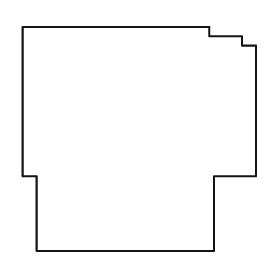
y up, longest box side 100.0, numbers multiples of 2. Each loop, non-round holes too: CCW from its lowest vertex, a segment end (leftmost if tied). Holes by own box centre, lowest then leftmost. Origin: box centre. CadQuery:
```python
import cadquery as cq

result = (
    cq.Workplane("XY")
    .moveTo(-44.0, -48.0)
    .lineTo(32.0, -48.0)
    .lineTo(32.0, -16.0)
    .lineTo(50.0, -16.0)
    .lineTo(50.0, 40.0)
    .lineTo(44.0, 40.0)
    .lineTo(44.0, 44.0)
    .lineTo(30.0, 44.0)
    .lineTo(30.0, 48.0)
    .lineTo(-50.0, 48.0)
    .lineTo(-50.0, -16.0)
    .lineTo(-44.0, -16.0)
    .close()
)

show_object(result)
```